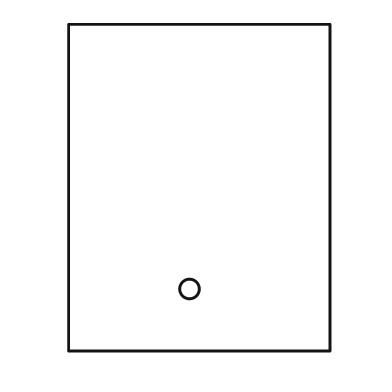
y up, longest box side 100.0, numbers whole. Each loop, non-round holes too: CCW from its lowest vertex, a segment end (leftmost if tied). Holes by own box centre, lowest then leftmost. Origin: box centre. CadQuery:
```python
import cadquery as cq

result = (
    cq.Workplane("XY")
    .moveTo(-40.0, -50.0)
    .lineTo(40.0, -50.0)
    .lineTo(40.0, 50.0)
    .lineTo(-40.0, 50.0)
    .close()
    .moveTo(-3.0, -31.0)
    .circle(3.0)
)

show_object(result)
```